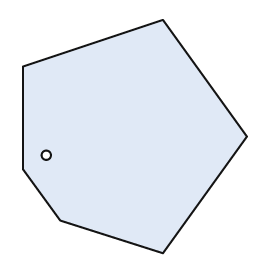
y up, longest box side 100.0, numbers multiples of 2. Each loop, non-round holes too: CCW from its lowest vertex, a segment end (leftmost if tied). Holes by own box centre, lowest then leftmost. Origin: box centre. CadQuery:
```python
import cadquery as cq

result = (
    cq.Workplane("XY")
    .moveTo(12.0, -50.0)
    .lineTo(48.0, 0.0)
    .lineTo(12.0, 50.0)
    .lineTo(-48.0, 30.0)
    .lineTo(-48.0, -14.0)
    .lineTo(-32.0, -36.0)
    .close()
    .moveTo(-38.0, -8.0)
    .circle(2.0)
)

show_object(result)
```